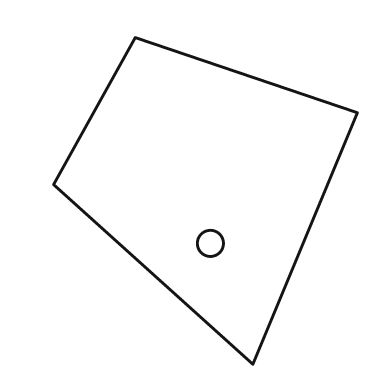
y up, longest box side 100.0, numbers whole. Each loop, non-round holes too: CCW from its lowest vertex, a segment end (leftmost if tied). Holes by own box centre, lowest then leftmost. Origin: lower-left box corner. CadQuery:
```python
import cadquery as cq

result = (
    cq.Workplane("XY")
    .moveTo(61.0, 0.0)
    .lineTo(93.0, 77.0)
    .lineTo(25.0, 100.0)
    .lineTo(0.0, 55.0)
    .close()
    .moveTo(48.0, 37.0)
    .circle(4.0)
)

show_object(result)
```